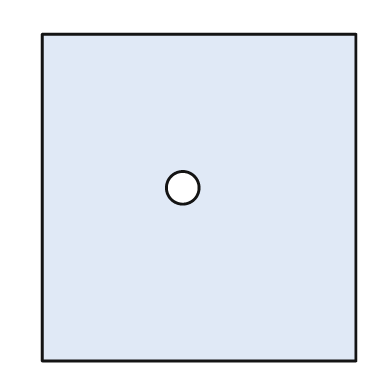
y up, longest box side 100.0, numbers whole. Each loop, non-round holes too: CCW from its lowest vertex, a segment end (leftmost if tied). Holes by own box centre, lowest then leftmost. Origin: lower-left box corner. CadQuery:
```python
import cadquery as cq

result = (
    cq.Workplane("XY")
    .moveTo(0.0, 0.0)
    .lineTo(96.0, 0.0)
    .lineTo(96.0, 100.0)
    .lineTo(0.0, 100.0)
    .close()
    .moveTo(43.0, 53.0)
    .circle(5.0)
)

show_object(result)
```